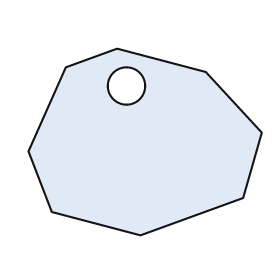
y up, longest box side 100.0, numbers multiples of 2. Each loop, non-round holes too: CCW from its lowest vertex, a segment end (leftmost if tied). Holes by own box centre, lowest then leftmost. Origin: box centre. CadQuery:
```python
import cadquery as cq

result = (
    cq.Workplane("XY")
    .moveTo(-2.0, -40.0)
    .lineTo(42.0, -24.0)
    .lineTo(50.0, 4.0)
    .lineTo(26.0, 30.0)
    .lineTo(-12.0, 40.0)
    .lineTo(-34.0, 32.0)
    .lineTo(-50.0, -4.0)
    .lineTo(-40.0, -30.0)
    .close()
    .moveTo(-8.0, 24.0)
    .circle(8.0)
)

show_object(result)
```